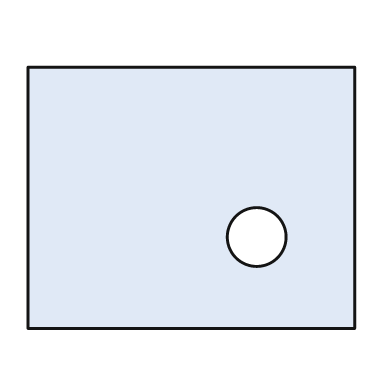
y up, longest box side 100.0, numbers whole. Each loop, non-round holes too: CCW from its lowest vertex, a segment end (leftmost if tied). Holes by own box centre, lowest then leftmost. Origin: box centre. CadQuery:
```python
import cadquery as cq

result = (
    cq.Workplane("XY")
    .moveTo(-50.0, -40.0)
    .lineTo(50.0, -40.0)
    .lineTo(50.0, 40.0)
    .lineTo(-50.0, 40.0)
    .close()
    .moveTo(20.0, -12.0)
    .circle(9.0)
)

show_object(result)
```